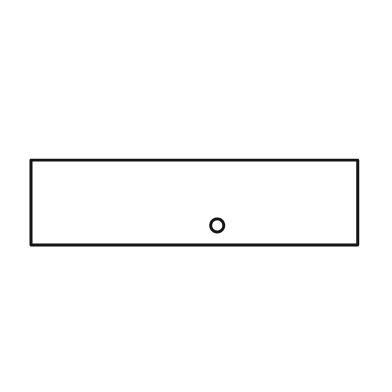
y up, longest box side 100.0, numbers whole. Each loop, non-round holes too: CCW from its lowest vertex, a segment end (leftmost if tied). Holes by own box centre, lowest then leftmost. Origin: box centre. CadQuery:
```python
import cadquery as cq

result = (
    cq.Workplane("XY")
    .moveTo(-50.0, -13.0)
    .lineTo(50.0, -13.0)
    .lineTo(50.0, 13.0)
    .lineTo(-50.0, 13.0)
    .close()
    .moveTo(7.0, -7.0)
    .circle(2.0)
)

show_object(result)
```